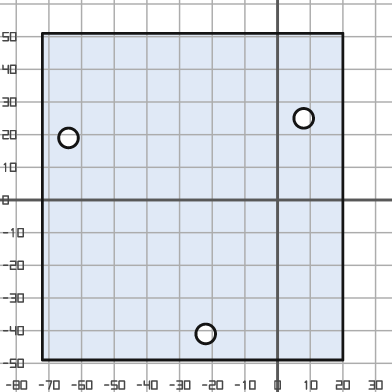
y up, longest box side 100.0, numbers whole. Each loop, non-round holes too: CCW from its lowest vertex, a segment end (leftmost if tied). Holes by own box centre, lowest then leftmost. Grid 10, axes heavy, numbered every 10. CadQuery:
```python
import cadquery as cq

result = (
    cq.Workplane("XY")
    .moveTo(-72.0, -49.0)
    .lineTo(20.0, -49.0)
    .lineTo(20.0, 51.0)
    .lineTo(-72.0, 51.0)
    .close()
    .moveTo(-22.0, -41.0)
    .circle(3.0)
    .moveTo(-64.0, 19.0)
    .circle(3.0)
    .moveTo(8.0, 25.0)
    .circle(3.0)
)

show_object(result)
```